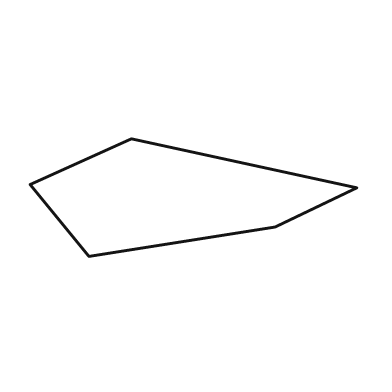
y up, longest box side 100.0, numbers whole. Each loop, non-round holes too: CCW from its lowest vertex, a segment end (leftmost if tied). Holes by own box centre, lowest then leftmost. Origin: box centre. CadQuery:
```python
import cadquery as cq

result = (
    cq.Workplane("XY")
    .moveTo(-32.0, -18.0)
    .lineTo(25.0, -9.0)
    .lineTo(50.0, 3.0)
    .lineTo(-19.0, 18.0)
    .lineTo(-50.0, 4.0)
    .close()
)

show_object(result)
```